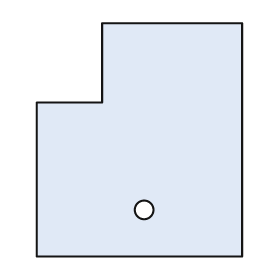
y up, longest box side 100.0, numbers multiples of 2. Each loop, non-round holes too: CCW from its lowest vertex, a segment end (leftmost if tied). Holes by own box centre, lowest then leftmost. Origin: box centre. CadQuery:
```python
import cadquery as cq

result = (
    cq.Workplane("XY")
    .moveTo(-44.0, -50.0)
    .lineTo(44.0, -50.0)
    .lineTo(44.0, 50.0)
    .lineTo(-16.0, 50.0)
    .lineTo(-16.0, 16.0)
    .lineTo(-44.0, 16.0)
    .close()
    .moveTo(2.0, -30.0)
    .circle(4.0)
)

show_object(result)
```